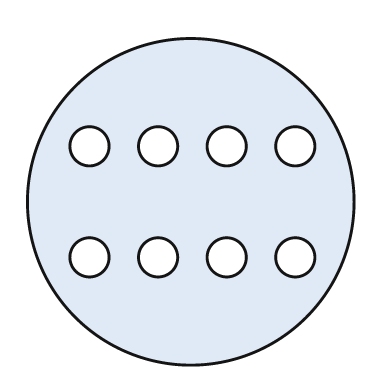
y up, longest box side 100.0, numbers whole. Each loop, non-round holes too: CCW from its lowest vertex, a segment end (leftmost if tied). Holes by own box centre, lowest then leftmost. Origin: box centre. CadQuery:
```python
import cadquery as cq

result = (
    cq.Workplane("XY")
    .moveTo(0.0, 0.0)
    .circle(50.0)
    .moveTo(-31.0, -17.0)
    .circle(6.0)
    .moveTo(-10.0, -17.0)
    .circle(6.0)
    .moveTo(11.0, -17.0)
    .circle(6.0)
    .moveTo(32.0, -17.0)
    .circle(6.0)
    .moveTo(-31.0, 17.0)
    .circle(6.0)
    .moveTo(-10.0, 17.0)
    .circle(6.0)
    .moveTo(11.0, 17.0)
    .circle(6.0)
    .moveTo(32.0, 17.0)
    .circle(6.0)
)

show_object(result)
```